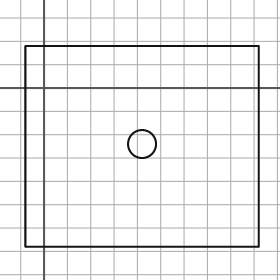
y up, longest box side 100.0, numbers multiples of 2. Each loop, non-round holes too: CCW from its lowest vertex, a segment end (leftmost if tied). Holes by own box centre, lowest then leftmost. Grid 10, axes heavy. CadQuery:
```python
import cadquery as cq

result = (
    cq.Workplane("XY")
    .moveTo(-8.0, -68.0)
    .lineTo(92.0, -68.0)
    .lineTo(92.0, 18.0)
    .lineTo(-8.0, 18.0)
    .close()
    .moveTo(42.0, -24.0)
    .circle(6.0)
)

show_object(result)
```